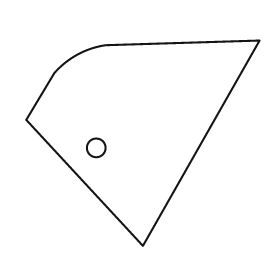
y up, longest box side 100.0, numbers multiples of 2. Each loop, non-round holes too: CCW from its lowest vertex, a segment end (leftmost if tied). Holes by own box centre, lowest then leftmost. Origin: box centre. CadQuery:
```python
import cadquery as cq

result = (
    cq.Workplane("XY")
    .moveTo(0.0, -44.0)
    .lineTo(50.0, 44.0)
    .lineTo(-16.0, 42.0)
    .threePointArc((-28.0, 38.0), (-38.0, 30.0))
    .lineTo(-50.0, 10.0)
    .close()
    .moveTo(-20.0, -2.0)
    .circle(4.0)
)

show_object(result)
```